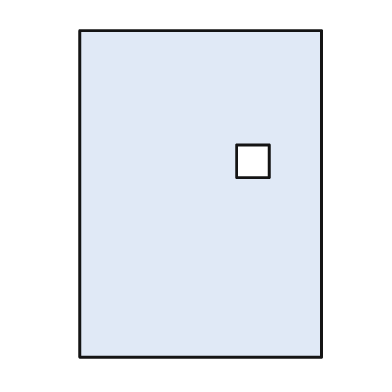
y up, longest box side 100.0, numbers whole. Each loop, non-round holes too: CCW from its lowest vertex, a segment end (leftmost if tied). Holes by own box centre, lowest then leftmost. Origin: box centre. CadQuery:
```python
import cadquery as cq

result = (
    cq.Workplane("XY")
    .moveTo(-37.0, -50.0)
    .lineTo(37.0, -50.0)
    .lineTo(37.0, 50.0)
    .lineTo(-37.0, 50.0)
    .close()
    .moveTo(11.0, 5.0)
    .lineTo(21.0, 5.0)
    .lineTo(21.0, 15.0)
    .lineTo(11.0, 15.0)
    .close()
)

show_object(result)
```